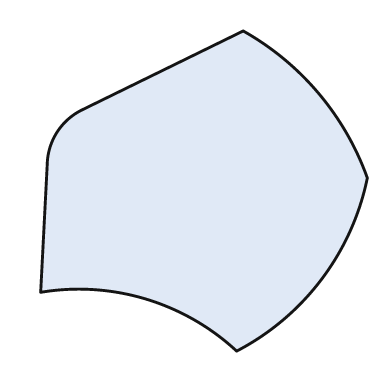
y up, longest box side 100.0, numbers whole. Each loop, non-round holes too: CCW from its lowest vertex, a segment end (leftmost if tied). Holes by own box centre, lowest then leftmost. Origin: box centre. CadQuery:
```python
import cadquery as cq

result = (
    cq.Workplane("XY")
    .moveTo(10.0, -49.0)
    .threePointArc((36.0, -27.0), (50.0, 4.0))
    .threePointArc((35.0, 30.0), (12.0, 49.0))
    .lineTo(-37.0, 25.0)
    .threePointArc((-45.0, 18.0), (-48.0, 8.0))
    .lineTo(-50.0, -31.0)
    .threePointArc((-18.0, -33.0), (10.0, -49.0))
    .close()
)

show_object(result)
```